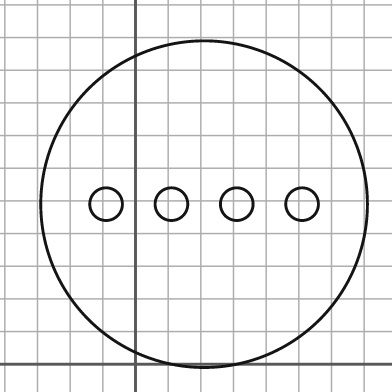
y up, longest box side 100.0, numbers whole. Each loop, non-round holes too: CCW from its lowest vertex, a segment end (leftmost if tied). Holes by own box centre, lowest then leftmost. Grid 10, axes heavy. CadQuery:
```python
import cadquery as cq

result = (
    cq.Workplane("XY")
    .moveTo(21.0, 49.0)
    .circle(50.0)
    .moveTo(-9.0, 49.0)
    .circle(5.0)
    .moveTo(11.0, 49.0)
    .circle(5.0)
    .moveTo(31.0, 49.0)
    .circle(5.0)
    .moveTo(51.0, 49.0)
    .circle(5.0)
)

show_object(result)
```